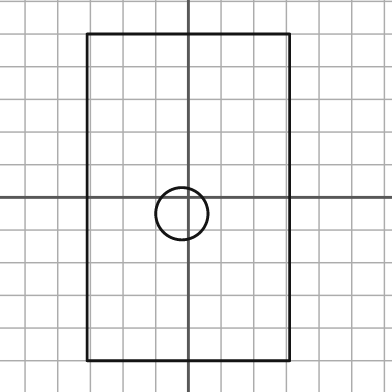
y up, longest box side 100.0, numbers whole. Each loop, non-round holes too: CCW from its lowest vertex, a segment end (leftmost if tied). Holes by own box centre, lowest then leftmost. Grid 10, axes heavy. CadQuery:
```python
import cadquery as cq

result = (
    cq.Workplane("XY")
    .moveTo(-31.0, -50.0)
    .lineTo(31.0, -50.0)
    .lineTo(31.0, 50.0)
    .lineTo(-31.0, 50.0)
    .close()
    .moveTo(-2.0, -5.0)
    .circle(8.0)
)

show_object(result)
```